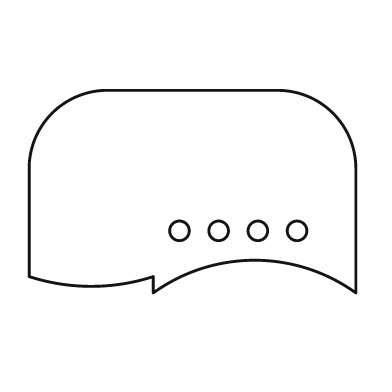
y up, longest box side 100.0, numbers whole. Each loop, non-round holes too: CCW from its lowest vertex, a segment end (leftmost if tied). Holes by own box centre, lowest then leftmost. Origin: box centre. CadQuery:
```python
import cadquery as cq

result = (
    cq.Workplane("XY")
    .moveTo(-12.0, -31.0)
    .threePointArc((19.0, -21.0), (50.0, -31.0))
    .lineTo(50.0, 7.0)
    .threePointArc((43.0, 24.0), (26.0, 31.0))
    .lineTo(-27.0, 31.0)
    .threePointArc((-43.0, 24.0), (-50.0, 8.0))
    .lineTo(-50.0, -26.0)
    .threePointArc((-31.0, -29.0), (-12.0, -26.0))
    .close()
    .moveTo(-4.0, -12.0)
    .circle(3.0)
    .moveTo(8.0, -12.0)
    .circle(3.0)
    .moveTo(20.0, -12.0)
    .circle(3.0)
    .moveTo(32.0, -12.0)
    .circle(3.0)
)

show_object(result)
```